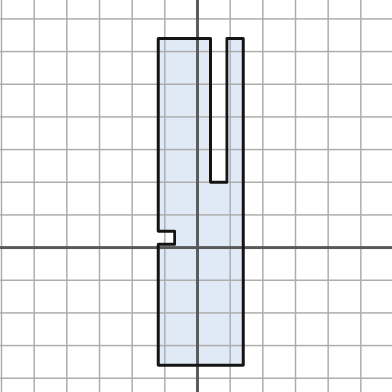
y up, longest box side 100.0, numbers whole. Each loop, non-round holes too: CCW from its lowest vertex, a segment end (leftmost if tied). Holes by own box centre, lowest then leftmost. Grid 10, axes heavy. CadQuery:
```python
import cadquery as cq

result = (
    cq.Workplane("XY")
    .moveTo(-12.0, -36.0)
    .lineTo(14.0, -36.0)
    .lineTo(14.0, 64.0)
    .lineTo(9.0, 64.0)
    .lineTo(9.0, 20.0)
    .lineTo(4.0, 20.0)
    .lineTo(4.0, 64.0)
    .lineTo(-12.0, 64.0)
    .lineTo(-12.0, 5.0)
    .lineTo(-7.0, 5.0)
    .lineTo(-7.0, 1.0)
    .lineTo(-12.0, 1.0)
    .close()
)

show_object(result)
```